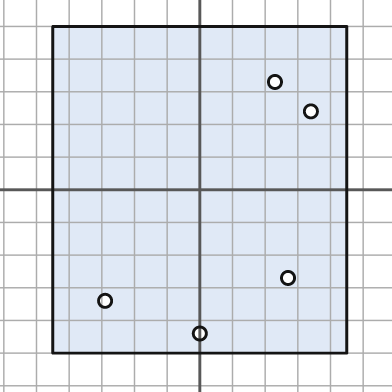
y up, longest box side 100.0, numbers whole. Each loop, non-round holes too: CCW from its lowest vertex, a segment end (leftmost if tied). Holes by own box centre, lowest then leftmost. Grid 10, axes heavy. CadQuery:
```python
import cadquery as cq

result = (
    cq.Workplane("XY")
    .moveTo(-45.0, -50.0)
    .lineTo(45.0, -50.0)
    .lineTo(45.0, 50.0)
    .lineTo(-45.0, 50.0)
    .close()
    .moveTo(0.0, -44.0)
    .circle(2.0)
    .moveTo(-29.0, -34.0)
    .circle(2.0)
    .moveTo(27.0, -27.0)
    .circle(2.0)
    .moveTo(34.0, 24.0)
    .circle(2.0)
    .moveTo(23.0, 33.0)
    .circle(2.0)
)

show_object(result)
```